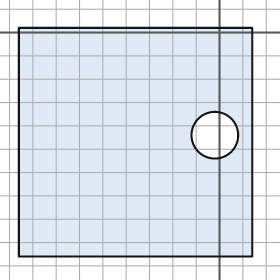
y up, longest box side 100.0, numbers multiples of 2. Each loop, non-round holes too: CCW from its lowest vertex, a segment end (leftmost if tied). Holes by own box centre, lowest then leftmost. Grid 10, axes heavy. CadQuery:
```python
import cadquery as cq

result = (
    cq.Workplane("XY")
    .moveTo(-86.0, -96.0)
    .lineTo(14.0, -96.0)
    .lineTo(14.0, 2.0)
    .lineTo(-86.0, 2.0)
    .close()
    .moveTo(-2.0, -44.0)
    .circle(10.0)
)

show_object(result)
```